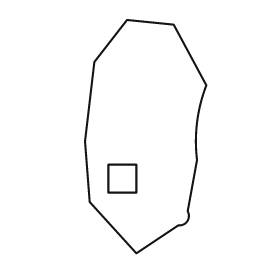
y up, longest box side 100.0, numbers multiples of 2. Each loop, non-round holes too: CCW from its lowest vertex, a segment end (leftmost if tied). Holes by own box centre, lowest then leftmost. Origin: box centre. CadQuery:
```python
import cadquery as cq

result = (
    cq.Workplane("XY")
    .moveTo(-4.0, -50.0)
    .lineTo(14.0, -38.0)
    .threePointArc((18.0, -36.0), (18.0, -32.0))
    .lineTo(22.0, -10.0)
    .threePointArc((22.0, 6.0), (26.0, 22.0))
    .lineTo(12.0, 48.0)
    .lineTo(-8.0, 50.0)
    .lineTo(-22.0, 32.0)
    .lineTo(-26.0, -2.0)
    .lineTo(-24.0, -28.0)
    .close()
    .moveTo(-16.0, -24.0)
    .lineTo(-4.0, -24.0)
    .lineTo(-4.0, -12.0)
    .lineTo(-16.0, -12.0)
    .close()
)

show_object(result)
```